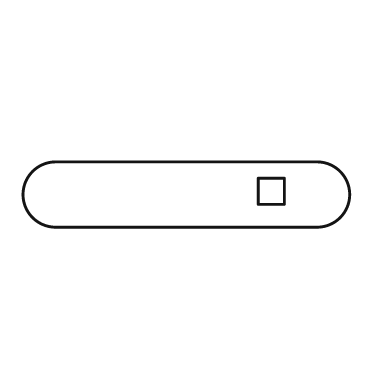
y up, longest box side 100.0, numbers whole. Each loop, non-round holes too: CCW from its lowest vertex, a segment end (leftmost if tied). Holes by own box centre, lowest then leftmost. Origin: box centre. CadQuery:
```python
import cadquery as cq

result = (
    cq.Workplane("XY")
    .moveTo(-40.0, -10.0)
    .lineTo(40.0, -10.0)
    .threePointArc((50.0, 0.0), (40.0, 10.0))
    .lineTo(-40.0, 10.0)
    .threePointArc((-50.0, 0.0), (-40.0, -10.0))
    .close()
    .moveTo(22.0, -3.0)
    .lineTo(30.0, -3.0)
    .lineTo(30.0, 5.0)
    .lineTo(22.0, 5.0)
    .close()
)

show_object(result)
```